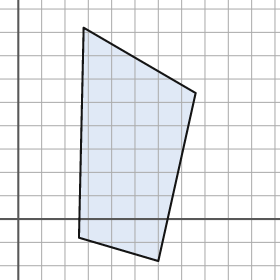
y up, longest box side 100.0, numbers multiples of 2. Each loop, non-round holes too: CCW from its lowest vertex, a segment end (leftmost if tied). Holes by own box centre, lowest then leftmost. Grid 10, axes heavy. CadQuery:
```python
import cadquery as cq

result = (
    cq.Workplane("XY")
    .moveTo(60.0, -18.0)
    .lineTo(76.0, 54.0)
    .lineTo(28.0, 82.0)
    .lineTo(26.0, -8.0)
    .close()
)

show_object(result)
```